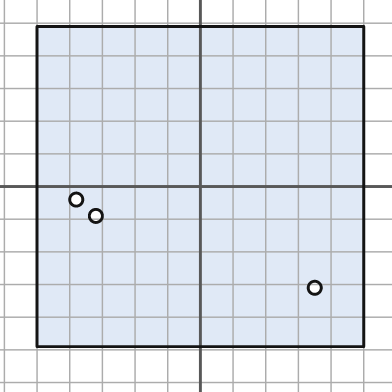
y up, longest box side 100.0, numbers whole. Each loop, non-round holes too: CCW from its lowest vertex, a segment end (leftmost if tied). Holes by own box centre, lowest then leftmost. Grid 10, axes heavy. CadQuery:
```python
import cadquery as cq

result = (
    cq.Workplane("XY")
    .moveTo(-50.0, -49.0)
    .lineTo(50.0, -49.0)
    .lineTo(50.0, 49.0)
    .lineTo(-50.0, 49.0)
    .close()
    .moveTo(35.0, -31.0)
    .circle(2.0)
    .moveTo(-32.0, -9.0)
    .circle(2.0)
    .moveTo(-38.0, -4.0)
    .circle(2.0)
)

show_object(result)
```